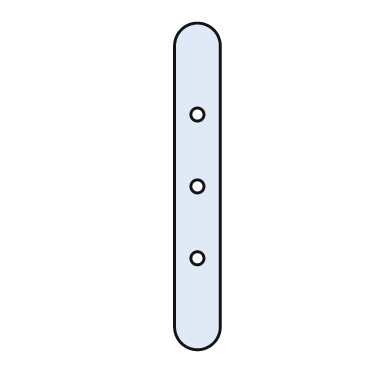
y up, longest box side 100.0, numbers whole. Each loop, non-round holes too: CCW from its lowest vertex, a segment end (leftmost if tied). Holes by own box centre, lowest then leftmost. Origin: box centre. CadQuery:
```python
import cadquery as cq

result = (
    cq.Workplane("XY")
    .moveTo(-7.0, -43.0)
    .threePointArc((0.0, -50.0), (7.0, -43.0))
    .lineTo(7.0, 43.0)
    .threePointArc((0.0, 50.0), (-7.0, 43.0))
    .close()
    .moveTo(0.0, -22.0)
    .circle(2.0)
    .moveTo(0.0, 0.0)
    .circle(2.0)
    .moveTo(0.0, 22.0)
    .circle(2.0)
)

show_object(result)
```